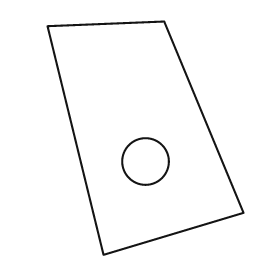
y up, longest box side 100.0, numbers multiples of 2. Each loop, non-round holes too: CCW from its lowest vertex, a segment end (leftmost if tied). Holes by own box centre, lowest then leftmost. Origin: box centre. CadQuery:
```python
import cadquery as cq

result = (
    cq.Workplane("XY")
    .moveTo(-18.0, -50.0)
    .lineTo(42.0, -32.0)
    .lineTo(8.0, 50.0)
    .lineTo(-42.0, 48.0)
    .close()
    .moveTo(0.0, -10.0)
    .circle(10.0)
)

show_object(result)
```